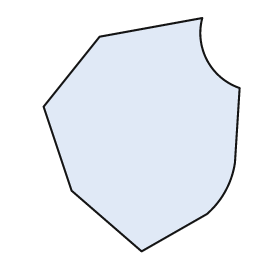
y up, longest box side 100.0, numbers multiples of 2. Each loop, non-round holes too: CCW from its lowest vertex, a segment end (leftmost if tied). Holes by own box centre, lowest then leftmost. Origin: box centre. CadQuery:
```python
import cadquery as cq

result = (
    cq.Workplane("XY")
    .moveTo(0.0, -50.0)
    .lineTo(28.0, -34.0)
    .threePointArc((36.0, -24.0), (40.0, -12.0))
    .lineTo(42.0, 20.0)
    .threePointArc((28.0, 32.0), (26.0, 50.0))
    .lineTo(-18.0, 42.0)
    .lineTo(-42.0, 12.0)
    .lineTo(-30.0, -24.0)
    .close()
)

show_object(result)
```